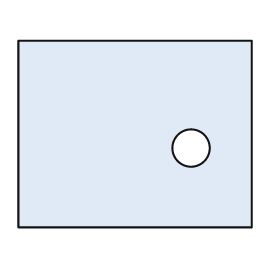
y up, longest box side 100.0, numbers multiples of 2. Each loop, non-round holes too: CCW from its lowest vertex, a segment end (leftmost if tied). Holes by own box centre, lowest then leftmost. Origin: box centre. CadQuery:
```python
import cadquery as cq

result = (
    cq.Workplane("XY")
    .moveTo(-50.0, -40.0)
    .lineTo(50.0, -40.0)
    .lineTo(50.0, 40.0)
    .lineTo(-50.0, 40.0)
    .close()
    .moveTo(24.0, -6.0)
    .circle(8.0)
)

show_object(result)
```